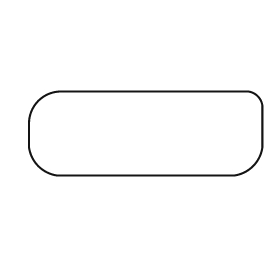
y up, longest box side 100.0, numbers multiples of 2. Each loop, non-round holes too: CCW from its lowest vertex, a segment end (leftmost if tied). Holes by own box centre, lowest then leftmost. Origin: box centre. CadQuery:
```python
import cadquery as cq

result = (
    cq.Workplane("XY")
    .moveTo(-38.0, -18.0)
    .lineTo(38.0, -18.0)
    .threePointArc((46.0, -14.0), (50.0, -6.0))
    .lineTo(50.0, 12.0)
    .threePointArc((48.0, 16.0), (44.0, 18.0))
    .lineTo(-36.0, 18.0)
    .threePointArc((-46.0, 14.0), (-50.0, 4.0))
    .lineTo(-50.0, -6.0)
    .threePointArc((-46.0, -14.0), (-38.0, -18.0))
    .close()
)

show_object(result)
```